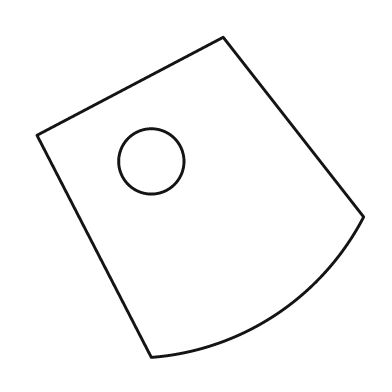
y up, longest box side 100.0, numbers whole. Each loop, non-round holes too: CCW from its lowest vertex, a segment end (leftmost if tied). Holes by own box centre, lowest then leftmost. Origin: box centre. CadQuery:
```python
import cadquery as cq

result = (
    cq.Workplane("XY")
    .moveTo(-15.0, -49.0)
    .threePointArc((23.0, -36.0), (50.0, -6.0))
    .lineTo(7.0, 49.0)
    .lineTo(-50.0, 19.0)
    .close()
    .moveTo(-15.0, 11.0)
    .circle(10.0)
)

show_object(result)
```